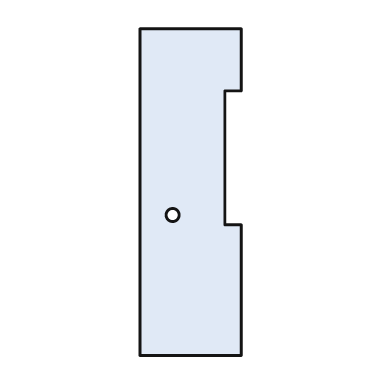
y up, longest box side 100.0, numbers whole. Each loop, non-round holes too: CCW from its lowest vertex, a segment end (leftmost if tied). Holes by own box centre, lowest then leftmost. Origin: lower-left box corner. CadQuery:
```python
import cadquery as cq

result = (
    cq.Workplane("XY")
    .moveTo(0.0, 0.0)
    .lineTo(31.0, 0.0)
    .lineTo(31.0, 40.0)
    .lineTo(26.0, 40.0)
    .lineTo(26.0, 81.0)
    .lineTo(31.0, 81.0)
    .lineTo(31.0, 100.0)
    .lineTo(0.0, 100.0)
    .close()
    .moveTo(10.0, 43.0)
    .circle(2.0)
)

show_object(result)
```